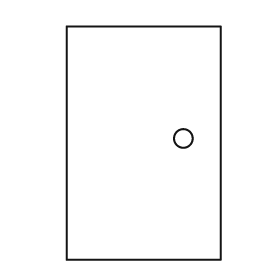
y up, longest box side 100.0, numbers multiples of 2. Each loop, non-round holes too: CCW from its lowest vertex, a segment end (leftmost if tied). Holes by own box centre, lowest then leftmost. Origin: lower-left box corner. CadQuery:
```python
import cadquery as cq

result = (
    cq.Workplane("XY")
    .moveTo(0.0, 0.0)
    .lineTo(66.0, 0.0)
    .lineTo(66.0, 100.0)
    .lineTo(0.0, 100.0)
    .close()
    .moveTo(50.0, 52.0)
    .circle(4.0)
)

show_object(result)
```